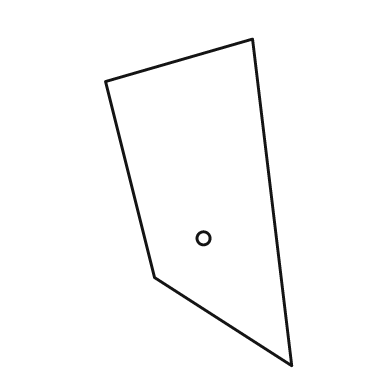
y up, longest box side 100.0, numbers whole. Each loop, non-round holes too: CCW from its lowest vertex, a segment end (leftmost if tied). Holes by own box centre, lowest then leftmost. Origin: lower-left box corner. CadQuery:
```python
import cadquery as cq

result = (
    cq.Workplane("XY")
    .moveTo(57.0, 0.0)
    .lineTo(45.0, 100.0)
    .lineTo(0.0, 87.0)
    .lineTo(15.0, 27.0)
    .close()
    .moveTo(30.0, 39.0)
    .circle(2.0)
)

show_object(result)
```